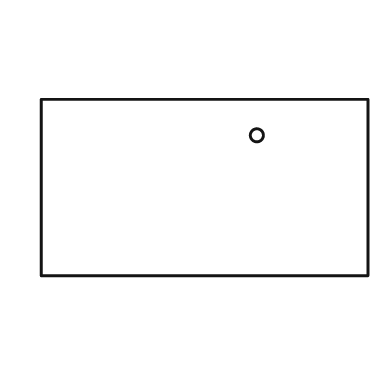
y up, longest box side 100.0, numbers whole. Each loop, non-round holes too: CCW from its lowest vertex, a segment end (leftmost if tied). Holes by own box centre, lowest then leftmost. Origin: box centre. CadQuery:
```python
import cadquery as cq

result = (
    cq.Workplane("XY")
    .moveTo(-50.0, -27.0)
    .lineTo(50.0, -27.0)
    .lineTo(50.0, 27.0)
    .lineTo(-50.0, 27.0)
    .close()
    .moveTo(16.0, 16.0)
    .circle(2.0)
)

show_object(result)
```